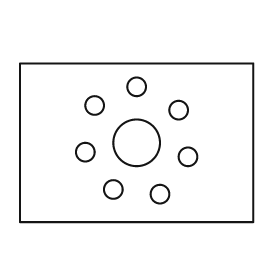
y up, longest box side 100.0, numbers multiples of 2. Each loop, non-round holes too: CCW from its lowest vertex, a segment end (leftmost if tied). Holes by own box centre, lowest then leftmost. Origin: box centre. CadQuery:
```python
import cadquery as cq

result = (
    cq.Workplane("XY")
    .moveTo(-50.0, -34.0)
    .lineTo(50.0, -34.0)
    .lineTo(50.0, 34.0)
    .lineTo(-50.0, 34.0)
    .close()
    .moveTo(10.0, -22.0)
    .circle(4.0)
    .moveTo(-10.0, -20.0)
    .circle(4.0)
    .moveTo(22.0, -6.0)
    .circle(4.0)
    .moveTo(-22.0, -4.0)
    .circle(4.0)
    .moveTo(0.0, 0.0)
    .circle(10.0)
    .moveTo(18.0, 14.0)
    .circle(4.0)
    .moveTo(-18.0, 16.0)
    .circle(4.0)
    .moveTo(0.0, 24.0)
    .circle(4.0)
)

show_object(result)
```